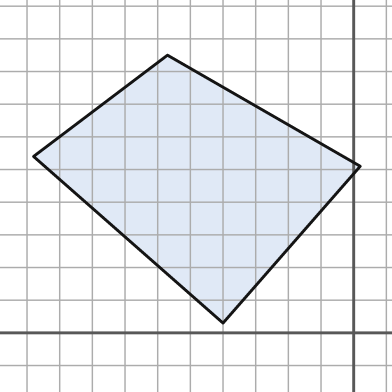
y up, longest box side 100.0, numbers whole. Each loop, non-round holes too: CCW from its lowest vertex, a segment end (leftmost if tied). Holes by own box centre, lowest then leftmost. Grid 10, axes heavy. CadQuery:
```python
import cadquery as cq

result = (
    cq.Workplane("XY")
    .moveTo(-40.0, 3.0)
    .lineTo(2.0, 51.0)
    .lineTo(-57.0, 85.0)
    .lineTo(-98.0, 54.0)
    .close()
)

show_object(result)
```